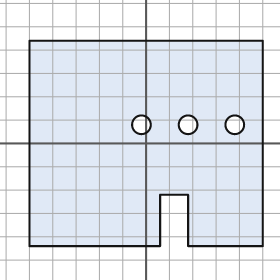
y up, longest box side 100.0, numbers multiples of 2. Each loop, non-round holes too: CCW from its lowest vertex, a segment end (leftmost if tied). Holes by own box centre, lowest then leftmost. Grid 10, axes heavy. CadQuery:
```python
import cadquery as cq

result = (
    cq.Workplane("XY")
    .moveTo(-50.0, -44.0)
    .lineTo(6.0, -44.0)
    .lineTo(6.0, -22.0)
    .lineTo(18.0, -22.0)
    .lineTo(18.0, -44.0)
    .lineTo(50.0, -44.0)
    .lineTo(50.0, 44.0)
    .lineTo(-50.0, 44.0)
    .close()
    .moveTo(-2.0, 8.0)
    .circle(4.0)
    .moveTo(18.0, 8.0)
    .circle(4.0)
    .moveTo(38.0, 8.0)
    .circle(4.0)
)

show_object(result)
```